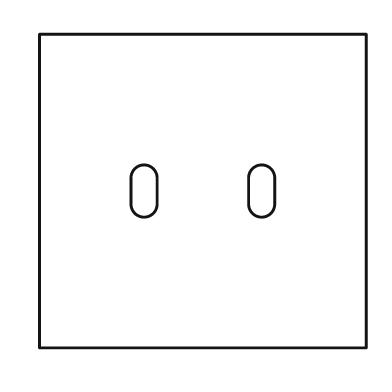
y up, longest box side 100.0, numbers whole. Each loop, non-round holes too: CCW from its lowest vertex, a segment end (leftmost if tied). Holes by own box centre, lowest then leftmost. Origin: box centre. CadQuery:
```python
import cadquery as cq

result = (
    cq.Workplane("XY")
    .moveTo(-50.0, -48.0)
    .lineTo(50.0, -48.0)
    .lineTo(50.0, 48.0)
    .lineTo(-50.0, 48.0)
    .close()
    .moveTo(-22.0, -4.0)
    .threePointArc((-18.0, -8.0), (-14.0, -4.0))
    .lineTo(-14.0, 4.0)
    .threePointArc((-18.0, 8.0), (-22.0, 4.0))
    .close()
    .moveTo(14.0, -4.0)
    .threePointArc((18.0, -8.0), (22.0, -4.0))
    .lineTo(22.0, 4.0)
    .threePointArc((18.0, 8.0), (14.0, 4.0))
    .close()
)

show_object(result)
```